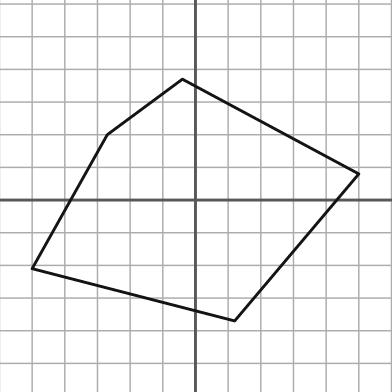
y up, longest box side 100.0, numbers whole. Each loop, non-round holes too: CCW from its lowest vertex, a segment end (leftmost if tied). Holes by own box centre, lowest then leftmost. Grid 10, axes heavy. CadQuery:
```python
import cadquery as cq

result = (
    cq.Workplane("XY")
    .moveTo(12.0, -37.0)
    .lineTo(50.0, 8.0)
    .lineTo(-4.0, 37.0)
    .lineTo(-27.0, 20.0)
    .lineTo(-50.0, -21.0)
    .close()
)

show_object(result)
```